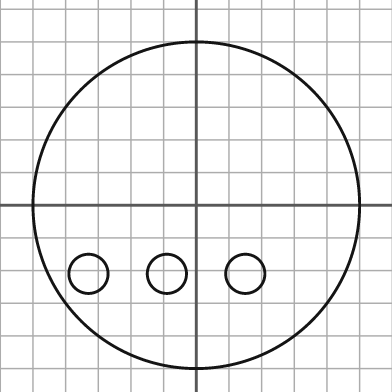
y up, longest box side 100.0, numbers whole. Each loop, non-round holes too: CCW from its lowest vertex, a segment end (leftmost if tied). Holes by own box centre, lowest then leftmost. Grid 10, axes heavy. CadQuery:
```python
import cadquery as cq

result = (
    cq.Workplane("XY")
    .moveTo(0.0, 0.0)
    .circle(50.0)
    .moveTo(-33.0, -21.0)
    .circle(6.0)
    .moveTo(-9.0, -21.0)
    .circle(6.0)
    .moveTo(15.0, -21.0)
    .circle(6.0)
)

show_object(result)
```